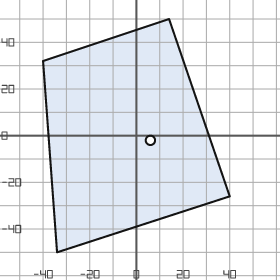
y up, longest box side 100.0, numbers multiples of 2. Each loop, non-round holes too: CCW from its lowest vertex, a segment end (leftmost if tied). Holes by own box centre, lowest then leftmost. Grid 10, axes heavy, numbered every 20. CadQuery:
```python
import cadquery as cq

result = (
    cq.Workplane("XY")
    .moveTo(-34.0, -50.0)
    .lineTo(40.0, -26.0)
    .lineTo(14.0, 50.0)
    .lineTo(-40.0, 32.0)
    .close()
    .moveTo(6.0, -2.0)
    .circle(2.0)
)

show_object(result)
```